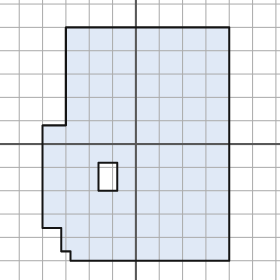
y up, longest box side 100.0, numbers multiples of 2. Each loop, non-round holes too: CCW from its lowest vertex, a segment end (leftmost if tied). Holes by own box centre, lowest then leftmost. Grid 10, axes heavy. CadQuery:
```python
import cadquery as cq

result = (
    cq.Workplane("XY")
    .moveTo(-28.0, -50.0)
    .lineTo(40.0, -50.0)
    .lineTo(40.0, 50.0)
    .lineTo(-30.0, 50.0)
    .lineTo(-30.0, 8.0)
    .lineTo(-40.0, 8.0)
    .lineTo(-40.0, -36.0)
    .lineTo(-32.0, -36.0)
    .lineTo(-32.0, -46.0)
    .lineTo(-28.0, -46.0)
    .close()
    .moveTo(-16.0, -20.0)
    .lineTo(-8.0, -20.0)
    .lineTo(-8.0, -8.0)
    .lineTo(-16.0, -8.0)
    .close()
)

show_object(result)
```